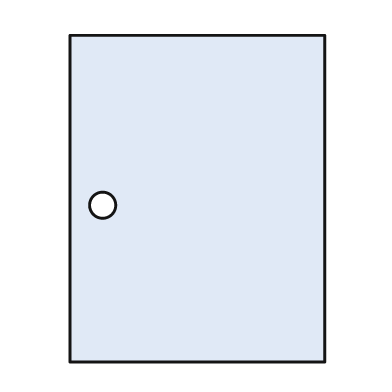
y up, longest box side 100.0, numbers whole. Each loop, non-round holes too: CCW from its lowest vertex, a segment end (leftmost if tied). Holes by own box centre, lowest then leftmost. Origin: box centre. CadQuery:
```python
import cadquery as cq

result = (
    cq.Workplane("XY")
    .moveTo(-39.0, -50.0)
    .lineTo(39.0, -50.0)
    .lineTo(39.0, 50.0)
    .lineTo(-39.0, 50.0)
    .close()
    .moveTo(-29.0, -2.0)
    .circle(4.0)
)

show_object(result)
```